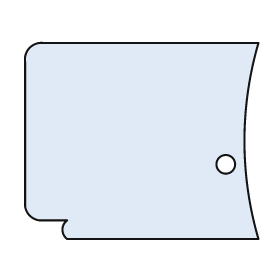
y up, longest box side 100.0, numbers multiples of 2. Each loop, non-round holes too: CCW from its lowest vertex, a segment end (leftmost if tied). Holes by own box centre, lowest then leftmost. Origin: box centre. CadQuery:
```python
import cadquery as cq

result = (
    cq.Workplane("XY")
    .moveTo(-32.0, -42.0)
    .lineTo(50.0, -42.0)
    .threePointArc((44.0, 0.0), (50.0, 42.0))
    .lineTo(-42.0, 42.0)
    .threePointArc((-48.0, 40.0), (-50.0, 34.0))
    .lineTo(-50.0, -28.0)
    .threePointArc((-48.0, -32.0), (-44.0, -34.0))
    .lineTo(-32.0, -34.0)
    .threePointArc((-34.0, -38.0), (-32.0, -42.0))
    .close()
    .moveTo(36.0, -10.0)
    .circle(4.0)
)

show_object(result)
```